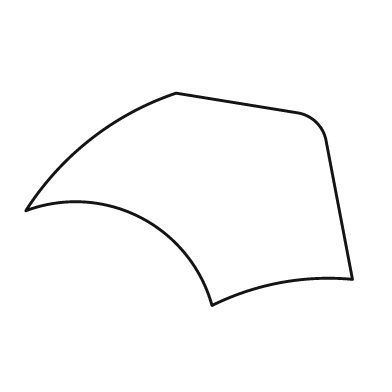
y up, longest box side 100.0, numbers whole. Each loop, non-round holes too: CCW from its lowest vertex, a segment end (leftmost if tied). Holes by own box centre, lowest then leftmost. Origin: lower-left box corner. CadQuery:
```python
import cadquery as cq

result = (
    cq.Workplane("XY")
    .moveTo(57.0, 0.0)
    .threePointArc((78.0, 7.0), (100.0, 8.0))
    .lineTo(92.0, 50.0)
    .threePointArc((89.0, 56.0), (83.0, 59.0))
    .lineTo(46.0, 65.0)
    .threePointArc((20.0, 51.0), (0.0, 29.0))
    .threePointArc((35.0, 27.0), (57.0, 0.0))
    .close()
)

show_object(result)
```